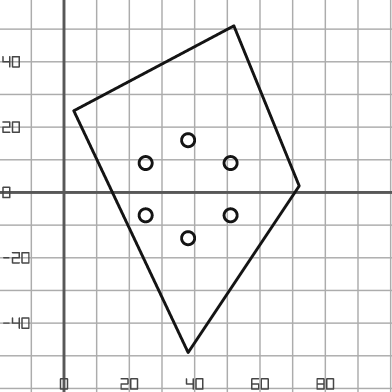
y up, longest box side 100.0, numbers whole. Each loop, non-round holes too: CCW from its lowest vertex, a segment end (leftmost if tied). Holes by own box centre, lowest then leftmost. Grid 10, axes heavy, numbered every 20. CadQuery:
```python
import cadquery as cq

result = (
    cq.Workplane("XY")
    .moveTo(38.0, -49.0)
    .lineTo(72.0, 2.0)
    .lineTo(52.0, 51.0)
    .lineTo(3.0, 25.0)
    .close()
    .moveTo(38.0, -14.0)
    .circle(2.0)
    .moveTo(25.0, -7.0)
    .circle(2.0)
    .moveTo(51.0, -7.0)
    .circle(2.0)
    .moveTo(25.0, 9.0)
    .circle(2.0)
    .moveTo(51.0, 9.0)
    .circle(2.0)
    .moveTo(38.0, 16.0)
    .circle(2.0)
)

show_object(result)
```